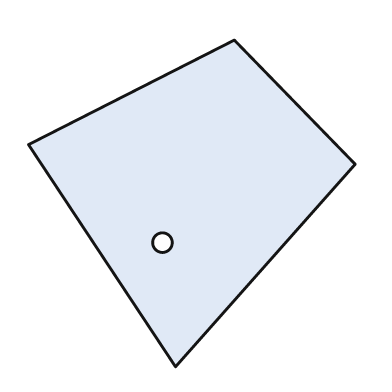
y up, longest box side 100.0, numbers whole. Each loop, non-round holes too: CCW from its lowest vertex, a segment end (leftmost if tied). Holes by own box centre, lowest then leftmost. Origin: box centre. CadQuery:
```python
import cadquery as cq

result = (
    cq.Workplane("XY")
    .moveTo(-5.0, -50.0)
    .lineTo(50.0, 12.0)
    .lineTo(13.0, 50.0)
    .lineTo(-50.0, 18.0)
    .close()
    .moveTo(-9.0, -12.0)
    .circle(3.0)
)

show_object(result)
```